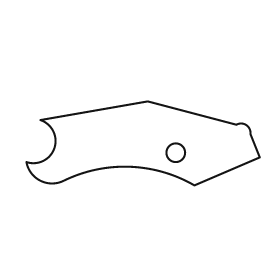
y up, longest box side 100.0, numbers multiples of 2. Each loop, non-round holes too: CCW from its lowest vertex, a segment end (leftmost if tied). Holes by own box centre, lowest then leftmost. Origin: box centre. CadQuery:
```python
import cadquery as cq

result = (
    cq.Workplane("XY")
    .moveTo(22.0, -18.0)
    .lineTo(50.0, -6.0)
    .lineTo(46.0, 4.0)
    .threePointArc((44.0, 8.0), (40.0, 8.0))
    .lineTo(2.0, 18.0)
    .lineTo(-44.0, 10.0)
    .threePointArc((-38.0, -2.0), (-50.0, -8.0))
    .threePointArc((-44.0, -16.0), (-34.0, -16.0))
    .threePointArc((-6.0, -10.0), (22.0, -18.0))
    .close()
    .moveTo(14.0, -4.0)
    .circle(4.0)
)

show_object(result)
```